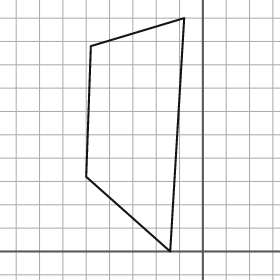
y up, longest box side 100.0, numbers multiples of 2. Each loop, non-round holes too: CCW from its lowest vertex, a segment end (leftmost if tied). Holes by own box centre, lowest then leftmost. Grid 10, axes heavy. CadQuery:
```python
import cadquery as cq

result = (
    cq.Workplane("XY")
    .moveTo(-14.0, 0.0)
    .lineTo(-8.0, 100.0)
    .lineTo(-48.0, 88.0)
    .lineTo(-50.0, 32.0)
    .close()
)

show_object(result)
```